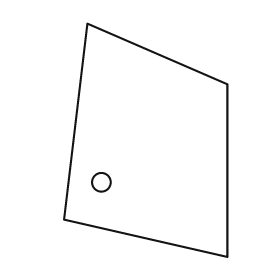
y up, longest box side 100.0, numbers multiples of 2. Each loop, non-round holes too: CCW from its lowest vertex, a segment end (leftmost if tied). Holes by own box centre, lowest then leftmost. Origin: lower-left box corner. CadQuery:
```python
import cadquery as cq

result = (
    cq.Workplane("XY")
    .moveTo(70.0, 0.0)
    .lineTo(70.0, 74.0)
    .lineTo(10.0, 100.0)
    .lineTo(0.0, 16.0)
    .close()
    .moveTo(16.0, 32.0)
    .circle(4.0)
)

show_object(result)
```